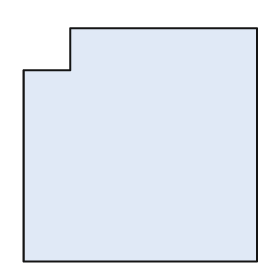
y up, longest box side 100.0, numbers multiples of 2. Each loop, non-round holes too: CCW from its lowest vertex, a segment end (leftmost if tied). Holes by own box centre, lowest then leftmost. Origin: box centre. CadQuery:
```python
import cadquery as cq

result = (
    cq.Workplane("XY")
    .moveTo(-50.0, -50.0)
    .lineTo(50.0, -50.0)
    .lineTo(50.0, 50.0)
    .lineTo(-30.0, 50.0)
    .lineTo(-30.0, 32.0)
    .lineTo(-50.0, 32.0)
    .close()
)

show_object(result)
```